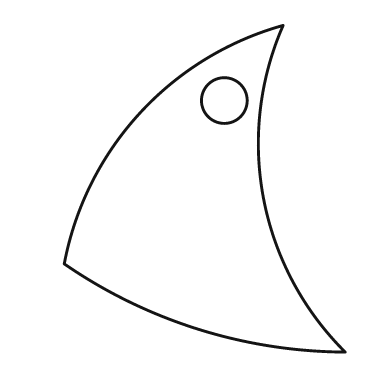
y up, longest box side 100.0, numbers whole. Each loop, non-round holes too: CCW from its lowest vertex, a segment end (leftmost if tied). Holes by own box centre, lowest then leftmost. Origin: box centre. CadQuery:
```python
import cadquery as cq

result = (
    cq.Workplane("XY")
    .moveTo(43.0, -50.0)
    .threePointArc((18.0, -3.0), (24.0, 50.0))
    .threePointArc((-20.0, 23.0), (-43.0, -23.0))
    .threePointArc((-2.0, -43.0), (43.0, -50.0))
    .close()
    .moveTo(6.0, 27.0)
    .circle(7.0)
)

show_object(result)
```